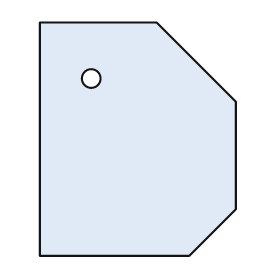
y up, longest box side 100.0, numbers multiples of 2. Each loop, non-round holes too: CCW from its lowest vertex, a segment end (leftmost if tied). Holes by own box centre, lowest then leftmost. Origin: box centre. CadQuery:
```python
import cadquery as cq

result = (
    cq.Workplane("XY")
    .moveTo(-42.0, -50.0)
    .lineTo(22.0, -50.0)
    .lineTo(42.0, -30.0)
    .lineTo(42.0, 16.0)
    .lineTo(8.0, 50.0)
    .lineTo(-42.0, 50.0)
    .close()
    .moveTo(-20.0, 26.0)
    .circle(4.0)
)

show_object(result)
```